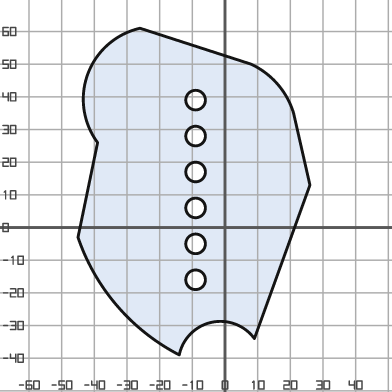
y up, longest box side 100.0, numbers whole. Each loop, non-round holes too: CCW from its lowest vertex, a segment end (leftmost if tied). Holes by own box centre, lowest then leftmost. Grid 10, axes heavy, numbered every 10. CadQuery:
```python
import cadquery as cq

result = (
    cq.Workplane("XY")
    .moveTo(-14.0, -39.0)
    .threePointArc((-4.0, -29.0), (9.0, -34.0))
    .lineTo(26.0, 13.0)
    .lineTo(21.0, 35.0)
    .threePointArc((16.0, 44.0), (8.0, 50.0))
    .lineTo(-26.0, 61.0)
    .threePointArc((-42.0, 47.0), (-39.0, 26.0))
    .lineTo(-45.0, -3.0)
    .threePointArc((-33.0, -24.0), (-14.0, -39.0))
    .close()
    .moveTo(-9.0, -16.0)
    .circle(3.0)
    .moveTo(-9.0, -5.0)
    .circle(3.0)
    .moveTo(-9.0, 6.0)
    .circle(3.0)
    .moveTo(-9.0, 17.0)
    .circle(3.0)
    .moveTo(-9.0, 28.0)
    .circle(3.0)
    .moveTo(-9.0, 39.0)
    .circle(3.0)
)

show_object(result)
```